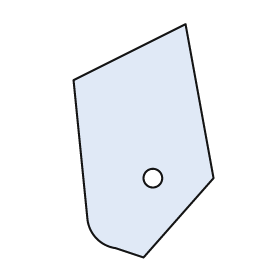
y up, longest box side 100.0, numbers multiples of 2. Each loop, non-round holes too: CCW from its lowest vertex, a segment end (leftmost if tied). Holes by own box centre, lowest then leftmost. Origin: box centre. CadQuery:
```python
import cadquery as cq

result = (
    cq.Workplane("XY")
    .moveTo(0.0, -50.0)
    .lineTo(30.0, -16.0)
    .lineTo(18.0, 50.0)
    .lineTo(-30.0, 26.0)
    .lineTo(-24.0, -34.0)
    .threePointArc((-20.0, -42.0), (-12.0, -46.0))
    .close()
    .moveTo(4.0, -16.0)
    .circle(4.0)
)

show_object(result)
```